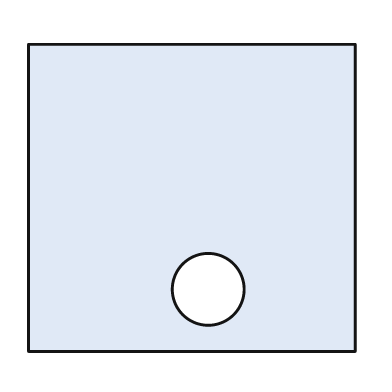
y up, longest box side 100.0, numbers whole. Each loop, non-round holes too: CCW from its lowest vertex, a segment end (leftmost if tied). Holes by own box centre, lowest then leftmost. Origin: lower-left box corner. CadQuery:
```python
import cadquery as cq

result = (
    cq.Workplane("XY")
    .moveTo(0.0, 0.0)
    .lineTo(100.0, 0.0)
    .lineTo(100.0, 94.0)
    .lineTo(0.0, 94.0)
    .close()
    .moveTo(55.0, 19.0)
    .circle(11.0)
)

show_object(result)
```